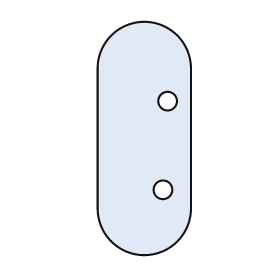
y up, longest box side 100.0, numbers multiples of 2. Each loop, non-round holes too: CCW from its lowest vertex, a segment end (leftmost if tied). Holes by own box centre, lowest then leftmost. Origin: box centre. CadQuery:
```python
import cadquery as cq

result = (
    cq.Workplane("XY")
    .moveTo(-20.0, -30.0)
    .threePointArc((0.0, -50.0), (20.0, -30.0))
    .lineTo(20.0, 30.0)
    .threePointArc((0.0, 50.0), (-20.0, 30.0))
    .close()
    .moveTo(8.0, -22.0)
    .circle(4.0)
    .moveTo(10.0, 16.0)
    .circle(4.0)
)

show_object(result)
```